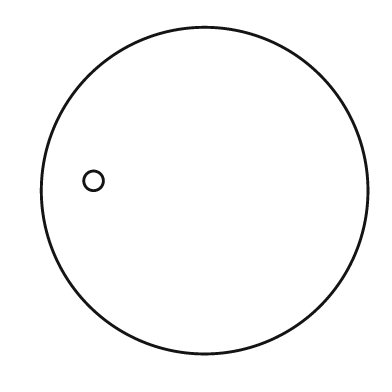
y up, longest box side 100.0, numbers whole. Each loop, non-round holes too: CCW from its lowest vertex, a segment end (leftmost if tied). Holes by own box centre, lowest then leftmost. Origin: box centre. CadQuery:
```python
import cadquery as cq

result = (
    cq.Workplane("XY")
    .moveTo(0.0, 0.0)
    .circle(50.0)
    .moveTo(-34.0, 3.0)
    .circle(3.0)
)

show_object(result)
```